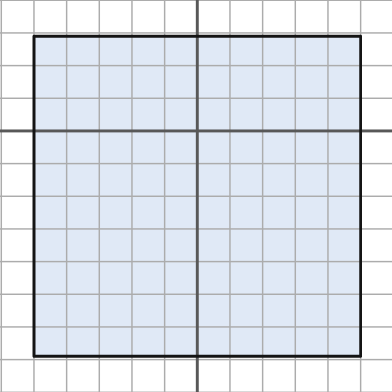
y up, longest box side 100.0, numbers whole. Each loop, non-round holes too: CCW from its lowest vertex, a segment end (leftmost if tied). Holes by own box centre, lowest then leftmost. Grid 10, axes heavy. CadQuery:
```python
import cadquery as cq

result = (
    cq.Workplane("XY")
    .moveTo(-50.0, -69.0)
    .lineTo(50.0, -69.0)
    .lineTo(50.0, 29.0)
    .lineTo(-50.0, 29.0)
    .close()
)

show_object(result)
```